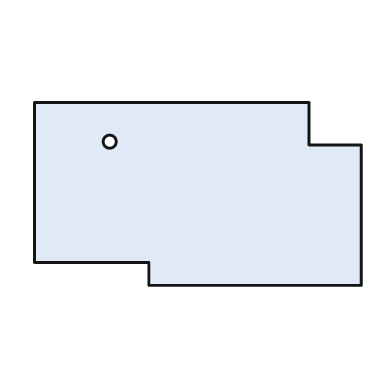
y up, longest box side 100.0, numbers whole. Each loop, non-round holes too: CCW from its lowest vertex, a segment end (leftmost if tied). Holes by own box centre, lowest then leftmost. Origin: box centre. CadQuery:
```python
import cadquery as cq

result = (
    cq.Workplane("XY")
    .moveTo(-15.0, -28.0)
    .lineTo(50.0, -28.0)
    .lineTo(50.0, 15.0)
    .lineTo(34.0, 15.0)
    .lineTo(34.0, 28.0)
    .lineTo(-50.0, 28.0)
    .lineTo(-50.0, -21.0)
    .lineTo(-15.0, -21.0)
    .close()
    .moveTo(-27.0, 16.0)
    .circle(2.0)
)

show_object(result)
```